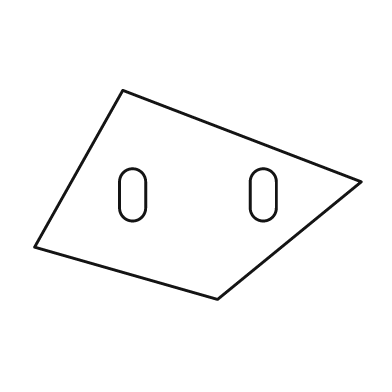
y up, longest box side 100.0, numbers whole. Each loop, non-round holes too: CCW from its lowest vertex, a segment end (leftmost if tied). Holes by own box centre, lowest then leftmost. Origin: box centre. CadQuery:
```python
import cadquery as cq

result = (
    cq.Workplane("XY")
    .moveTo(6.0, -32.0)
    .lineTo(50.0, 4.0)
    .lineTo(-23.0, 32.0)
    .lineTo(-50.0, -16.0)
    .close()
    .moveTo(-24.0, -4.0)
    .threePointArc((-20.0, -8.0), (-16.0, -4.0))
    .lineTo(-16.0, 4.0)
    .threePointArc((-20.0, 8.0), (-24.0, 4.0))
    .close()
    .moveTo(16.0, -4.0)
    .threePointArc((20.0, -8.0), (24.0, -4.0))
    .lineTo(24.0, 4.0)
    .threePointArc((20.0, 8.0), (16.0, 4.0))
    .close()
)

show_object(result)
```